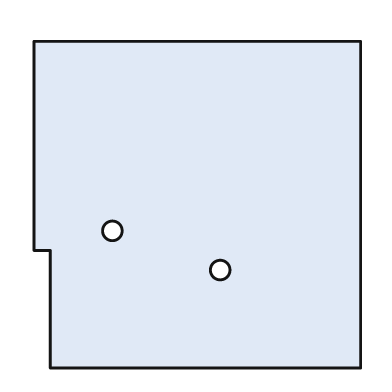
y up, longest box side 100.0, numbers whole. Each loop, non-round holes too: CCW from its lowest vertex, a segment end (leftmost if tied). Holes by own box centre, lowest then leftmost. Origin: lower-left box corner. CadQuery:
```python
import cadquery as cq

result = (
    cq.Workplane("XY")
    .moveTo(5.0, 0.0)
    .lineTo(100.0, 0.0)
    .lineTo(100.0, 100.0)
    .lineTo(0.0, 100.0)
    .lineTo(0.0, 36.0)
    .lineTo(5.0, 36.0)
    .close()
    .moveTo(57.0, 30.0)
    .circle(3.0)
    .moveTo(24.0, 42.0)
    .circle(3.0)
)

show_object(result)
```